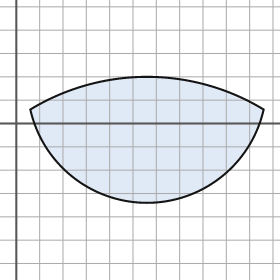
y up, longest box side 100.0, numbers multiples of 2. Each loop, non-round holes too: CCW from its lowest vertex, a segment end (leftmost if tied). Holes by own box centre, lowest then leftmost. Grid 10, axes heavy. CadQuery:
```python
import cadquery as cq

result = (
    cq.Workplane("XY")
    .moveTo(6.0, 6.0)
    .threePointArc((56.0, -34.0), (106.0, 6.0))
    .threePointArc((56.0, 20.0), (6.0, 6.0))
    .close()
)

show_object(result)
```